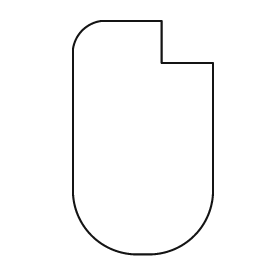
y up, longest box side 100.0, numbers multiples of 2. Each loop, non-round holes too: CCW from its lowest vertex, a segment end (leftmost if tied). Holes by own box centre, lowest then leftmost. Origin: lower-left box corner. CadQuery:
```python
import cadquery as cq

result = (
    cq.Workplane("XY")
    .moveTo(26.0, 0.0)
    .lineTo(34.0, 0.0)
    .threePointArc((52.0, 8.0), (60.0, 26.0))
    .lineTo(60.0, 82.0)
    .lineTo(38.0, 82.0)
    .lineTo(38.0, 100.0)
    .lineTo(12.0, 100.0)
    .threePointArc((4.0, 96.0), (0.0, 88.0))
    .lineTo(0.0, 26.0)
    .threePointArc((8.0, 8.0), (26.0, 0.0))
    .close()
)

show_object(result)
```